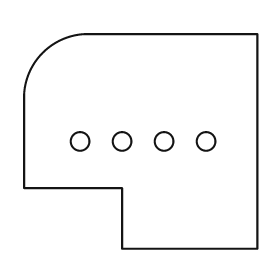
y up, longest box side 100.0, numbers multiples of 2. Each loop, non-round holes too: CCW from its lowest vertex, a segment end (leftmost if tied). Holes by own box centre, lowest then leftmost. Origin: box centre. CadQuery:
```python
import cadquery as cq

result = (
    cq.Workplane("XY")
    .moveTo(-8.0, -46.0)
    .lineTo(50.0, -46.0)
    .lineTo(50.0, 46.0)
    .lineTo(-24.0, 46.0)
    .threePointArc((-42.0, 38.0), (-50.0, 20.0))
    .lineTo(-50.0, -20.0)
    .lineTo(-8.0, -20.0)
    .close()
    .moveTo(-26.0, 0.0)
    .circle(4.0)
    .moveTo(-8.0, 0.0)
    .circle(4.0)
    .moveTo(10.0, 0.0)
    .circle(4.0)
    .moveTo(28.0, 0.0)
    .circle(4.0)
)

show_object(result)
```